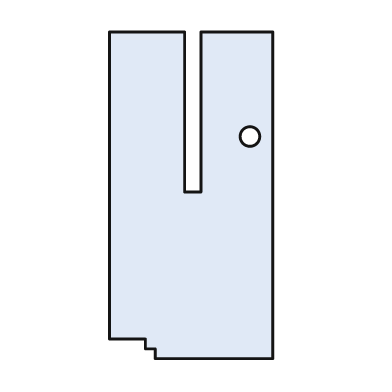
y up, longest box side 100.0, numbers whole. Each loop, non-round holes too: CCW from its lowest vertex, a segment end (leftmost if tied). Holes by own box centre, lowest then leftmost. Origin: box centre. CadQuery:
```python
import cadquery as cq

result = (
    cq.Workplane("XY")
    .moveTo(-11.0, -50.0)
    .lineTo(25.0, -50.0)
    .lineTo(25.0, 50.0)
    .lineTo(3.0, 50.0)
    .lineTo(3.0, 1.0)
    .lineTo(-2.0, 1.0)
    .lineTo(-2.0, 50.0)
    .lineTo(-25.0, 50.0)
    .lineTo(-25.0, -44.0)
    .lineTo(-14.0, -44.0)
    .lineTo(-14.0, -47.0)
    .lineTo(-11.0, -47.0)
    .close()
    .moveTo(18.0, 18.0)
    .circle(3.0)
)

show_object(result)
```